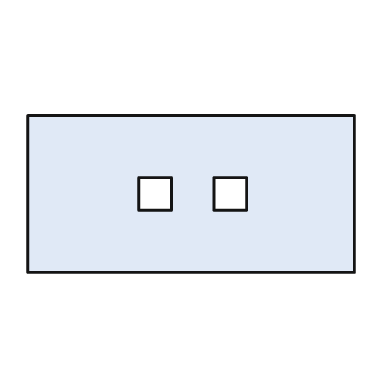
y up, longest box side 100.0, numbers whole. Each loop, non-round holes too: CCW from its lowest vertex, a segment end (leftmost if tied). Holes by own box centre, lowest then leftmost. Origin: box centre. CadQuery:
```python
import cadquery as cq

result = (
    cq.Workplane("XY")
    .moveTo(-50.0, -24.0)
    .lineTo(50.0, -24.0)
    .lineTo(50.0, 24.0)
    .lineTo(-50.0, 24.0)
    .close()
    .moveTo(-16.0, -5.0)
    .lineTo(-6.0, -5.0)
    .lineTo(-6.0, 5.0)
    .lineTo(-16.0, 5.0)
    .close()
    .moveTo(7.0, -5.0)
    .lineTo(17.0, -5.0)
    .lineTo(17.0, 5.0)
    .lineTo(7.0, 5.0)
    .close()
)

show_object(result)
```